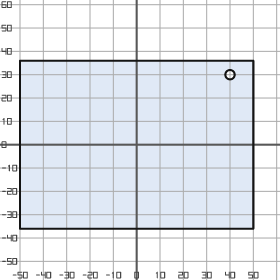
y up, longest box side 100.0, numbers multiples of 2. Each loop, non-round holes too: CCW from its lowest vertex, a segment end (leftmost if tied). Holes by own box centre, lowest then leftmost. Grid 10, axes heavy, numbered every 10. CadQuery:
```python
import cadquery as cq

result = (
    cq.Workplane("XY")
    .moveTo(-50.0, -36.0)
    .lineTo(50.0, -36.0)
    .lineTo(50.0, 36.0)
    .lineTo(-50.0, 36.0)
    .close()
    .moveTo(40.0, 30.0)
    .circle(2.0)
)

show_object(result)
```